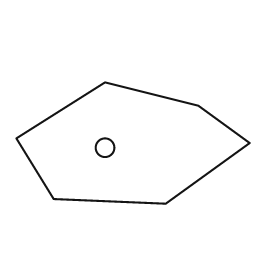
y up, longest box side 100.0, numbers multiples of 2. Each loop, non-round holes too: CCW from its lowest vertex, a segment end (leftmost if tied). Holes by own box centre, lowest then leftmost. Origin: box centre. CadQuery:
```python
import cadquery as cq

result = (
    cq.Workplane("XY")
    .moveTo(14.0, -26.0)
    .lineTo(50.0, 0.0)
    .lineTo(28.0, 16.0)
    .lineTo(-12.0, 26.0)
    .lineTo(-50.0, 2.0)
    .lineTo(-34.0, -24.0)
    .close()
    .moveTo(-12.0, -2.0)
    .circle(4.0)
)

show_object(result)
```